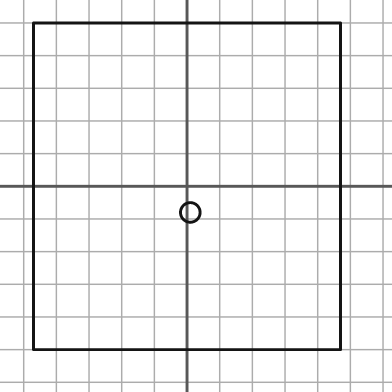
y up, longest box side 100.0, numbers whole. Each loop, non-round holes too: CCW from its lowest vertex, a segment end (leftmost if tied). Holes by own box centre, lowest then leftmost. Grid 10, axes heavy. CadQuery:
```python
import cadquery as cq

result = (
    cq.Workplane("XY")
    .moveTo(-47.0, -50.0)
    .lineTo(47.0, -50.0)
    .lineTo(47.0, 50.0)
    .lineTo(-47.0, 50.0)
    .close()
    .moveTo(1.0, -8.0)
    .circle(3.0)
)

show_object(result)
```